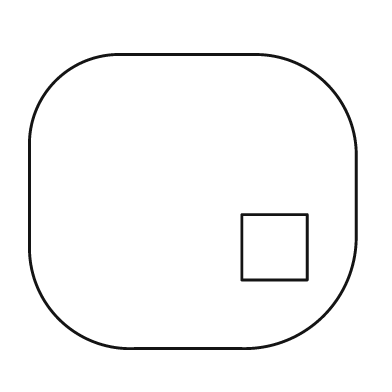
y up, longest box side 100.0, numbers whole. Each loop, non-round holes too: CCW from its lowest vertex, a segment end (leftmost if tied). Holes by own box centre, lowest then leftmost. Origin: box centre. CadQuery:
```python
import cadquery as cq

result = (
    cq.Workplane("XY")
    .moveTo(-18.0, -45.0)
    .lineTo(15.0, -45.0)
    .threePointArc((40.0, -35.0), (50.0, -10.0))
    .lineTo(50.0, 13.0)
    .threePointArc((41.0, 36.0), (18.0, 45.0))
    .lineTo(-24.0, 45.0)
    .threePointArc((-42.0, 37.0), (-50.0, 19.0))
    .lineTo(-50.0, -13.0)
    .threePointArc((-41.0, -36.0), (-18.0, -45.0))
    .close()
    .moveTo(15.0, -24.0)
    .lineTo(35.0, -24.0)
    .lineTo(35.0, -4.0)
    .lineTo(15.0, -4.0)
    .close()
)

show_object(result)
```